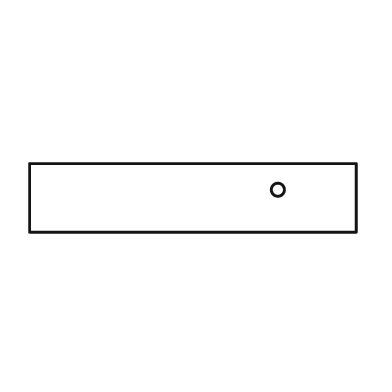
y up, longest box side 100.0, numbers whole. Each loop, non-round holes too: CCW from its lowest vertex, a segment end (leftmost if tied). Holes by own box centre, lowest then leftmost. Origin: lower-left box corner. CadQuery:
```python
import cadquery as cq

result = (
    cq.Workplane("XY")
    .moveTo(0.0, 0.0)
    .lineTo(100.0, 0.0)
    .lineTo(100.0, 21.0)
    .lineTo(0.0, 21.0)
    .close()
    .moveTo(76.0, 13.0)
    .circle(2.0)
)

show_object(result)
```